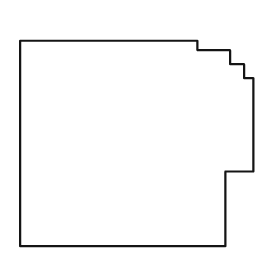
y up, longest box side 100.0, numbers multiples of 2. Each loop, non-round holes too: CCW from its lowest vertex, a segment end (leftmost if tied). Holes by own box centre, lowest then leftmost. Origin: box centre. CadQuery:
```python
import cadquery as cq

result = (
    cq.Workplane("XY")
    .moveTo(-50.0, -44.0)
    .lineTo(38.0, -44.0)
    .lineTo(38.0, -12.0)
    .lineTo(50.0, -12.0)
    .lineTo(50.0, 28.0)
    .lineTo(46.0, 28.0)
    .lineTo(46.0, 34.0)
    .lineTo(40.0, 34.0)
    .lineTo(40.0, 40.0)
    .lineTo(26.0, 40.0)
    .lineTo(26.0, 44.0)
    .lineTo(-50.0, 44.0)
    .close()
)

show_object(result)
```